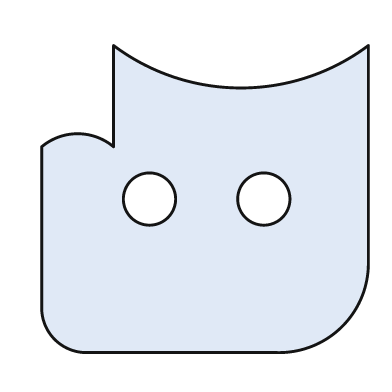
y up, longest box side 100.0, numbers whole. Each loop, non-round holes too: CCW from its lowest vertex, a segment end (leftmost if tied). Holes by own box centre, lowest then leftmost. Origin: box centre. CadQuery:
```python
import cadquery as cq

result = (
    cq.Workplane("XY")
    .moveTo(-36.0, -47.0)
    .lineTo(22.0, -47.0)
    .threePointArc((42.0, -39.0), (50.0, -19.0))
    .lineTo(50.0, 47.0)
    .threePointArc((11.0, 34.0), (-28.0, 47.0))
    .lineTo(-28.0, 16.0)
    .threePointArc((-39.0, 20.0), (-50.0, 16.0))
    .lineTo(-50.0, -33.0)
    .threePointArc((-46.0, -43.0), (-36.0, -47.0))
    .close()
    .moveTo(-17.0, 0.0)
    .circle(8.0)
    .moveTo(18.0, 0.0)
    .circle(8.0)
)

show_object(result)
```